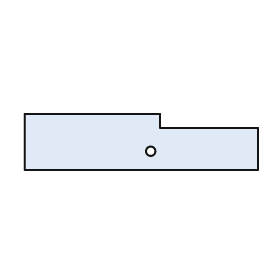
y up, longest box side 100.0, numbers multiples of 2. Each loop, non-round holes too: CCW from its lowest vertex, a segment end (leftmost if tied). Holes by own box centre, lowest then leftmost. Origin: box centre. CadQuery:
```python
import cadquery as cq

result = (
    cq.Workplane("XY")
    .moveTo(-50.0, -12.0)
    .lineTo(50.0, -12.0)
    .lineTo(50.0, 6.0)
    .lineTo(8.0, 6.0)
    .lineTo(8.0, 12.0)
    .lineTo(-50.0, 12.0)
    .close()
    .moveTo(4.0, -4.0)
    .circle(2.0)
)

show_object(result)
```